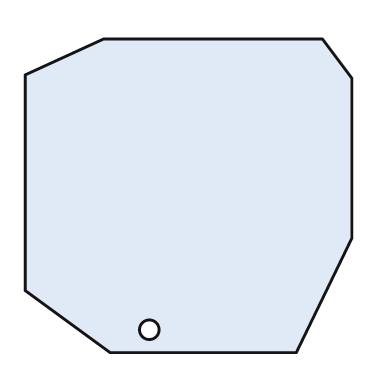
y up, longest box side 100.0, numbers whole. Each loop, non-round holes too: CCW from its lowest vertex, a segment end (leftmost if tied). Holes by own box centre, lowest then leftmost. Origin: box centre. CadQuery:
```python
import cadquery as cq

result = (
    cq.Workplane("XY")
    .moveTo(-24.0, -48.0)
    .lineTo(33.0, -48.0)
    .lineTo(50.0, -13.0)
    .lineTo(50.0, 36.0)
    .lineTo(41.0, 48.0)
    .lineTo(-26.0, 48.0)
    .lineTo(-50.0, 37.0)
    .lineTo(-50.0, -29.0)
    .close()
    .moveTo(-12.0, -41.0)
    .circle(3.0)
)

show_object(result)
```